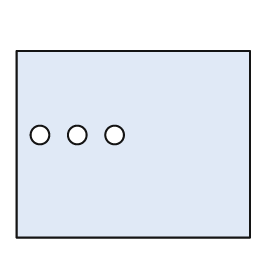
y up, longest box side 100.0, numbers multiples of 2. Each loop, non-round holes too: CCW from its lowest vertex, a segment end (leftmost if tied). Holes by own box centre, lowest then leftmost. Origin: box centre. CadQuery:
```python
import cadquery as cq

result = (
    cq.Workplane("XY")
    .moveTo(-50.0, -40.0)
    .lineTo(50.0, -40.0)
    .lineTo(50.0, 40.0)
    .lineTo(-50.0, 40.0)
    .close()
    .moveTo(-40.0, 4.0)
    .circle(4.0)
    .moveTo(-24.0, 4.0)
    .circle(4.0)
    .moveTo(-8.0, 4.0)
    .circle(4.0)
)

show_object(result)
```